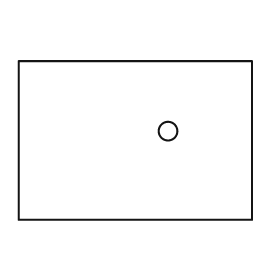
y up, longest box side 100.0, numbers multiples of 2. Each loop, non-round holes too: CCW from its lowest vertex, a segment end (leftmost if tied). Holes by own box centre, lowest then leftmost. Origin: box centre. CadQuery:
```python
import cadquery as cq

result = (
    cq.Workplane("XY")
    .moveTo(-50.0, -34.0)
    .lineTo(50.0, -34.0)
    .lineTo(50.0, 34.0)
    .lineTo(-50.0, 34.0)
    .close()
    .moveTo(14.0, 4.0)
    .circle(4.0)
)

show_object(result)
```